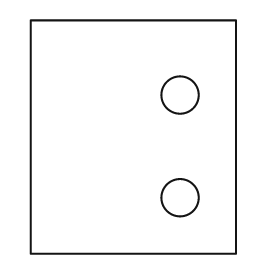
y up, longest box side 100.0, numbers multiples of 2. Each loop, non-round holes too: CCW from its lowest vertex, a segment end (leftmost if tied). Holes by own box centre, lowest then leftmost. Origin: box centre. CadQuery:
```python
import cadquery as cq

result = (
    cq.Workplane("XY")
    .moveTo(-44.0, -50.0)
    .lineTo(44.0, -50.0)
    .lineTo(44.0, 50.0)
    .lineTo(-44.0, 50.0)
    .close()
    .moveTo(20.0, -26.0)
    .circle(8.0)
    .moveTo(20.0, 18.0)
    .circle(8.0)
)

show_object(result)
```